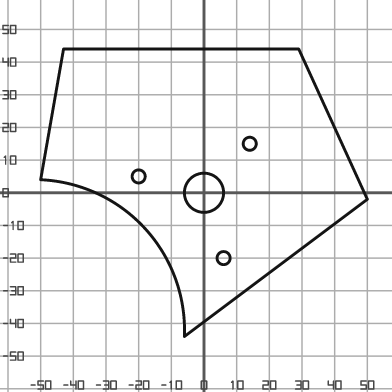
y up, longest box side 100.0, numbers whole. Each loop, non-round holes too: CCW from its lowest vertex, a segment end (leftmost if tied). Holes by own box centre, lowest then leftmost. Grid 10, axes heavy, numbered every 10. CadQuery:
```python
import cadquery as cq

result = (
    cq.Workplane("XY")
    .moveTo(-6.0, -44.0)
    .lineTo(50.0, -2.0)
    .lineTo(29.0, 44.0)
    .lineTo(-43.0, 44.0)
    .lineTo(-50.0, 4.0)
    .threePointArc((-18.0, -11.0), (-6.0, -44.0))
    .close()
    .moveTo(6.0, -20.0)
    .circle(2.0)
    .moveTo(0.0, 0.0)
    .circle(6.0)
    .moveTo(-20.0, 5.0)
    .circle(2.0)
    .moveTo(14.0, 15.0)
    .circle(2.0)
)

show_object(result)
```